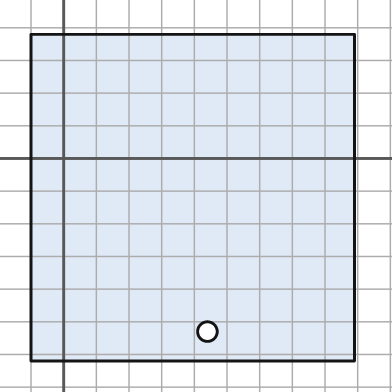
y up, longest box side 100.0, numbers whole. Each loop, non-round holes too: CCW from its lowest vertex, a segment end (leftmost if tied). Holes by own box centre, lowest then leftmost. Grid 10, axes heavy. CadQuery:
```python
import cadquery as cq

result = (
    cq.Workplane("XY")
    .moveTo(-10.0, -62.0)
    .lineTo(89.0, -62.0)
    .lineTo(89.0, 38.0)
    .lineTo(-10.0, 38.0)
    .close()
    .moveTo(44.0, -53.0)
    .circle(3.0)
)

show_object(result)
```